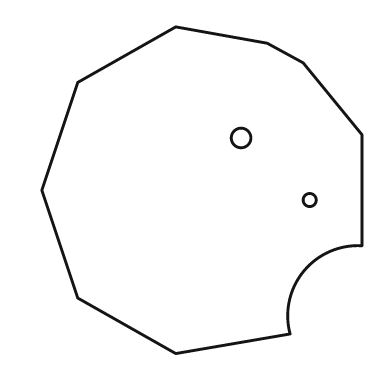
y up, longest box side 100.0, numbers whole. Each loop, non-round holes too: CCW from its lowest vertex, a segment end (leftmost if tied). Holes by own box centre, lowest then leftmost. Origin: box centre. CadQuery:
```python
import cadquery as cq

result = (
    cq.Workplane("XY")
    .moveTo(-8.0, -50.0)
    .lineTo(27.0, -44.0)
    .threePointArc((31.0, -25.0), (49.0, -17.0))
    .lineTo(49.0, 17.0)
    .lineTo(31.0, 39.0)
    .lineTo(20.0, 45.0)
    .lineTo(-8.0, 50.0)
    .lineTo(-38.0, 33.0)
    .lineTo(-49.0, 0.0)
    .lineTo(-38.0, -33.0)
    .close()
    .moveTo(33.0, -3.0)
    .circle(2.0)
    .moveTo(12.0, 16.0)
    .circle(3.0)
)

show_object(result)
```